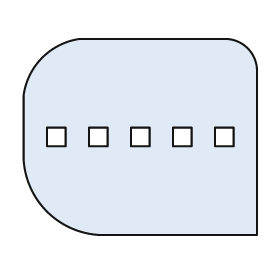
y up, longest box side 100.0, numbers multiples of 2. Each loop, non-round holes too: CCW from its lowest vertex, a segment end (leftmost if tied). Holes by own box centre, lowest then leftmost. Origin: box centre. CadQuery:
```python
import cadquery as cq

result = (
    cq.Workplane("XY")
    .moveTo(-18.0, -42.0)
    .lineTo(50.0, -42.0)
    .lineTo(50.0, 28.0)
    .threePointArc((46.0, 38.0), (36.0, 42.0))
    .lineTo(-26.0, 42.0)
    .threePointArc((-42.0, 34.0), (-50.0, 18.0))
    .lineTo(-50.0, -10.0)
    .threePointArc((-40.0, -32.0), (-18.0, -42.0))
    .close()
    .moveTo(-40.0, -4.0)
    .lineTo(-32.0, -4.0)
    .lineTo(-32.0, 4.0)
    .lineTo(-40.0, 4.0)
    .close()
    .moveTo(-22.0, -4.0)
    .lineTo(-14.0, -4.0)
    .lineTo(-14.0, 4.0)
    .lineTo(-22.0, 4.0)
    .close()
    .moveTo(-4.0, -4.0)
    .lineTo(4.0, -4.0)
    .lineTo(4.0, 4.0)
    .lineTo(-4.0, 4.0)
    .close()
    .moveTo(14.0, -4.0)
    .lineTo(22.0, -4.0)
    .lineTo(22.0, 4.0)
    .lineTo(14.0, 4.0)
    .close()
    .moveTo(32.0, -4.0)
    .lineTo(40.0, -4.0)
    .lineTo(40.0, 4.0)
    .lineTo(32.0, 4.0)
    .close()
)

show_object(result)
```